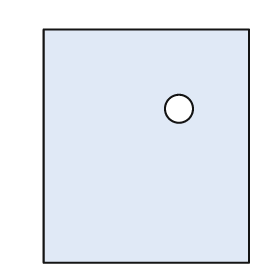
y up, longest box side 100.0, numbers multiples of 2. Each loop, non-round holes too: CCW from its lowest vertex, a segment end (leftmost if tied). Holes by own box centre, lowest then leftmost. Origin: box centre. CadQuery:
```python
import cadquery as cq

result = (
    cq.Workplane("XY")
    .moveTo(-44.0, -50.0)
    .lineTo(44.0, -50.0)
    .lineTo(44.0, 50.0)
    .lineTo(-44.0, 50.0)
    .close()
    .moveTo(14.0, 16.0)
    .circle(6.0)
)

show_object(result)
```